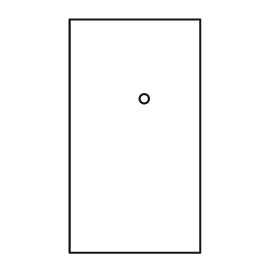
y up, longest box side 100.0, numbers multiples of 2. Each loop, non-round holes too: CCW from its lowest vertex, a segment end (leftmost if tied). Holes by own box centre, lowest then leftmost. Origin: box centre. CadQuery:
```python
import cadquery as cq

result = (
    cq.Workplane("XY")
    .moveTo(-28.0, -50.0)
    .lineTo(28.0, -50.0)
    .lineTo(28.0, 50.0)
    .lineTo(-28.0, 50.0)
    .close()
    .moveTo(4.0, 16.0)
    .circle(2.0)
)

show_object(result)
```